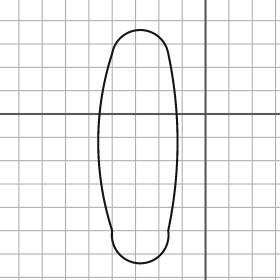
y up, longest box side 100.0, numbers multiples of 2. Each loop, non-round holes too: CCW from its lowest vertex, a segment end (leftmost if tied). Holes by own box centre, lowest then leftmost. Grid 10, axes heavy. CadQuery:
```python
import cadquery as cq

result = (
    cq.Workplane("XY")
    .moveTo(-40.0, -50.0)
    .threePointArc((-28.0, -64.0), (-16.0, -50.0))
    .threePointArc((-12.0, -12.0), (-16.0, 26.0))
    .threePointArc((-28.0, 36.0), (-40.0, 26.0))
    .threePointArc((-46.0, -12.0), (-40.0, -50.0))
    .close()
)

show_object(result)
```